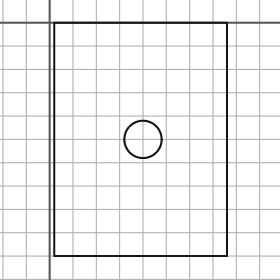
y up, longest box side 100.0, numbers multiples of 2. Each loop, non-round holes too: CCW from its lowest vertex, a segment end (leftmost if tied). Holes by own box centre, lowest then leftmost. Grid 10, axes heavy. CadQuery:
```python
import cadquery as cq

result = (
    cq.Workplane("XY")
    .moveTo(2.0, -100.0)
    .lineTo(76.0, -100.0)
    .lineTo(76.0, 0.0)
    .lineTo(2.0, 0.0)
    .close()
    .moveTo(40.0, -50.0)
    .circle(8.0)
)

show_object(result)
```